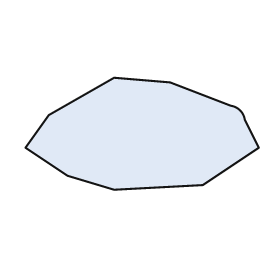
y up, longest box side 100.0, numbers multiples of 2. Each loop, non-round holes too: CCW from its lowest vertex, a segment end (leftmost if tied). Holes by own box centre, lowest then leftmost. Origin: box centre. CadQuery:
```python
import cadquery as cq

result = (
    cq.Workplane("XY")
    .moveTo(-12.0, -24.0)
    .lineTo(26.0, -22.0)
    .lineTo(50.0, -6.0)
    .lineTo(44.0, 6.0)
    .threePointArc((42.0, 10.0), (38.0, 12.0))
    .lineTo(12.0, 22.0)
    .lineTo(-12.0, 24.0)
    .lineTo(-40.0, 8.0)
    .lineTo(-50.0, -6.0)
    .lineTo(-32.0, -18.0)
    .close()
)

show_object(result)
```